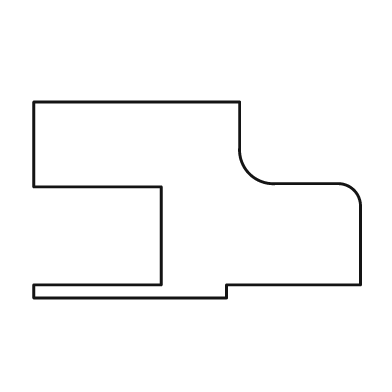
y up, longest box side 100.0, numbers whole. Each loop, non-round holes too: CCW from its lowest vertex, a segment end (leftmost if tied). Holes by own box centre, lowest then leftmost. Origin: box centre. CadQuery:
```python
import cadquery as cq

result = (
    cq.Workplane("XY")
    .moveTo(-50.0, -30.0)
    .lineTo(9.0, -30.0)
    .lineTo(9.0, -26.0)
    .lineTo(50.0, -26.0)
    .lineTo(50.0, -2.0)
    .threePointArc((48.0, 3.0), (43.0, 5.0))
    .lineTo(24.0, 5.0)
    .threePointArc((16.0, 8.0), (13.0, 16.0))
    .lineTo(13.0, 30.0)
    .lineTo(-50.0, 30.0)
    .lineTo(-50.0, 4.0)
    .lineTo(-11.0, 4.0)
    .lineTo(-11.0, -26.0)
    .lineTo(-50.0, -26.0)
    .close()
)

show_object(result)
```